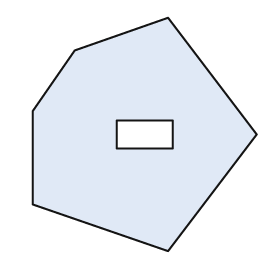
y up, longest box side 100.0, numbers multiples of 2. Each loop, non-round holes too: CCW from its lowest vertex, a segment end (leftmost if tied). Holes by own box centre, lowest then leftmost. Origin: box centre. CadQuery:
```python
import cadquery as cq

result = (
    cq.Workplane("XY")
    .moveTo(10.0, -50.0)
    .lineTo(48.0, 0.0)
    .lineTo(10.0, 50.0)
    .lineTo(-30.0, 36.0)
    .lineTo(-48.0, 10.0)
    .lineTo(-48.0, -30.0)
    .close()
    .moveTo(-12.0, -6.0)
    .lineTo(12.0, -6.0)
    .lineTo(12.0, 6.0)
    .lineTo(-12.0, 6.0)
    .close()
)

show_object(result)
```